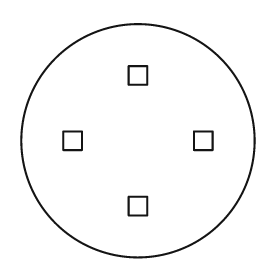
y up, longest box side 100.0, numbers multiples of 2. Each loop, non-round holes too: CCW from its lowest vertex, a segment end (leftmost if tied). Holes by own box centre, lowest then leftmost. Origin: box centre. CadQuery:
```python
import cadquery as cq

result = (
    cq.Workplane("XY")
    .moveTo(0.0, 0.0)
    .circle(50.0)
    .moveTo(-4.0, -32.0)
    .lineTo(4.0, -32.0)
    .lineTo(4.0, -24.0)
    .lineTo(-4.0, -24.0)
    .close()
    .moveTo(-32.0, -4.0)
    .lineTo(-24.0, -4.0)
    .lineTo(-24.0, 4.0)
    .lineTo(-32.0, 4.0)
    .close()
    .moveTo(24.0, -4.0)
    .lineTo(32.0, -4.0)
    .lineTo(32.0, 4.0)
    .lineTo(24.0, 4.0)
    .close()
    .moveTo(-4.0, 24.0)
    .lineTo(4.0, 24.0)
    .lineTo(4.0, 32.0)
    .lineTo(-4.0, 32.0)
    .close()
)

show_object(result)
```